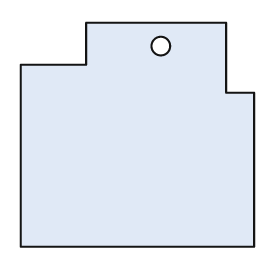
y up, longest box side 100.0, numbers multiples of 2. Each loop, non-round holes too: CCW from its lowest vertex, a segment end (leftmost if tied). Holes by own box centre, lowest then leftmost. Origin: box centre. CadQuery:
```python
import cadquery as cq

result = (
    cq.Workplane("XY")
    .moveTo(-50.0, -48.0)
    .lineTo(50.0, -48.0)
    .lineTo(50.0, 18.0)
    .lineTo(38.0, 18.0)
    .lineTo(38.0, 48.0)
    .lineTo(-22.0, 48.0)
    .lineTo(-22.0, 30.0)
    .lineTo(-50.0, 30.0)
    .close()
    .moveTo(10.0, 38.0)
    .circle(4.0)
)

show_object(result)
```